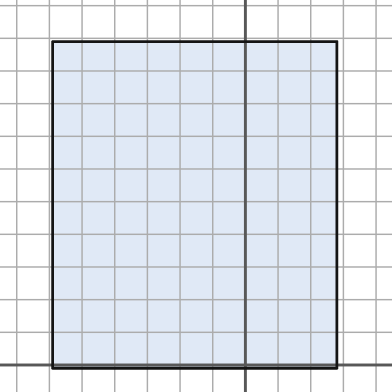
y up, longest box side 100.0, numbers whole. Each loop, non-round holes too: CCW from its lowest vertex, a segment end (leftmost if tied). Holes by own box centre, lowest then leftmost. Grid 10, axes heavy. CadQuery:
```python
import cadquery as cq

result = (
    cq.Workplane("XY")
    .moveTo(-59.0, -1.0)
    .lineTo(28.0, -1.0)
    .lineTo(28.0, 99.0)
    .lineTo(-59.0, 99.0)
    .close()
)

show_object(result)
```